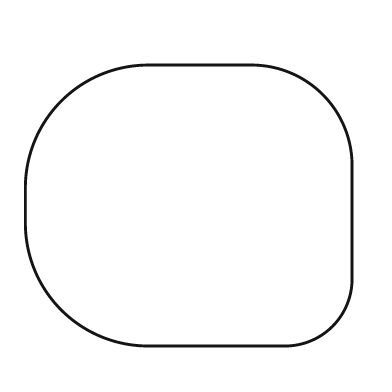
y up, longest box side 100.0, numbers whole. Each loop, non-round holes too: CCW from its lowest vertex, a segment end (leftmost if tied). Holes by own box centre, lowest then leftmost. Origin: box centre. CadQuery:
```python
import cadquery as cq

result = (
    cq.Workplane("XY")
    .moveTo(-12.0, -43.0)
    .lineTo(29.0, -43.0)
    .threePointArc((44.0, -37.0), (50.0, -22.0))
    .lineTo(50.0, 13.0)
    .threePointArc((41.0, 34.0), (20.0, 43.0))
    .lineTo(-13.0, 43.0)
    .threePointArc((-39.0, 32.0), (-50.0, 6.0))
    .lineTo(-50.0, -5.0)
    .threePointArc((-39.0, -32.0), (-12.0, -43.0))
    .close()
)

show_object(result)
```